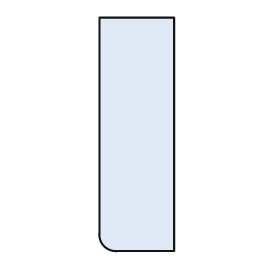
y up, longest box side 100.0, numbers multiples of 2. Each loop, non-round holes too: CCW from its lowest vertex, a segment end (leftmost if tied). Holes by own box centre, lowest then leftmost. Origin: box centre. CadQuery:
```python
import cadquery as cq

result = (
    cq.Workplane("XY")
    .moveTo(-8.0, -50.0)
    .lineTo(16.0, -50.0)
    .lineTo(16.0, 50.0)
    .lineTo(-16.0, 50.0)
    .lineTo(-16.0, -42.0)
    .threePointArc((-14.0, -48.0), (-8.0, -50.0))
    .close()
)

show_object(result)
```